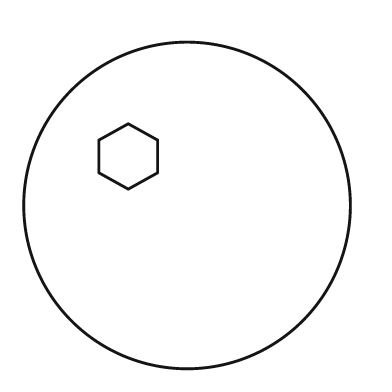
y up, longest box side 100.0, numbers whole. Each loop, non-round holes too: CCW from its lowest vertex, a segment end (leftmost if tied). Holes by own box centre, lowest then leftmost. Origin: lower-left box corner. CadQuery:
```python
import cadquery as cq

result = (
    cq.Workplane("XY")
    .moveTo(50.0, 50.0)
    .circle(50.0)
    .moveTo(32.0, 55.0)
    .lineTo(41.0, 60.0)
    .lineTo(41.0, 70.0)
    .lineTo(32.0, 75.0)
    .lineTo(23.0, 70.0)
    .lineTo(23.0, 60.0)
    .close()
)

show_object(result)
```